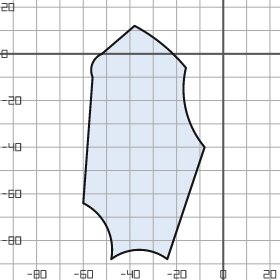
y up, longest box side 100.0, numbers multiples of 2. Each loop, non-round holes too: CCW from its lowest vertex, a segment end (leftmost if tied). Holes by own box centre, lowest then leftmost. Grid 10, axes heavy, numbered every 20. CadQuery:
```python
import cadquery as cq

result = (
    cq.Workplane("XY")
    .moveTo(-48.0, -88.0)
    .threePointArc((-36.0, -84.0), (-24.0, -88.0))
    .lineTo(-8.0, -40.0)
    .threePointArc((-16.0, -24.0), (-16.0, -6.0))
    .threePointArc((-26.0, 4.0), (-38.0, 12.0))
    .lineTo(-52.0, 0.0)
    .threePointArc((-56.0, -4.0), (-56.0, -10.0))
    .lineTo(-60.0, -64.0)
    .threePointArc((-50.0, -74.0), (-48.0, -88.0))
    .close()
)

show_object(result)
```